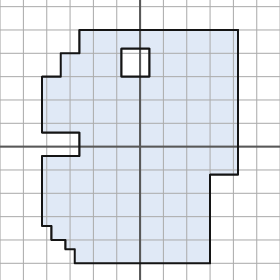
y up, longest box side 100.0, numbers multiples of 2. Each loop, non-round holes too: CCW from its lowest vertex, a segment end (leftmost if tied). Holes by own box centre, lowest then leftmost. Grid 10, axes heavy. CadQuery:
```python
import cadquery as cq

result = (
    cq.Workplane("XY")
    .moveTo(-28.0, -50.0)
    .lineTo(30.0, -50.0)
    .lineTo(30.0, -12.0)
    .lineTo(42.0, -12.0)
    .lineTo(42.0, 50.0)
    .lineTo(-26.0, 50.0)
    .lineTo(-26.0, 40.0)
    .lineTo(-34.0, 40.0)
    .lineTo(-34.0, 30.0)
    .lineTo(-42.0, 30.0)
    .lineTo(-42.0, 6.0)
    .lineTo(-26.0, 6.0)
    .lineTo(-26.0, -4.0)
    .lineTo(-42.0, -4.0)
    .lineTo(-42.0, -34.0)
    .lineTo(-38.0, -34.0)
    .lineTo(-38.0, -40.0)
    .lineTo(-32.0, -40.0)
    .lineTo(-32.0, -44.0)
    .lineTo(-28.0, -44.0)
    .close()
    .moveTo(-8.0, 30.0)
    .lineTo(4.0, 30.0)
    .lineTo(4.0, 42.0)
    .lineTo(-8.0, 42.0)
    .close()
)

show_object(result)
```